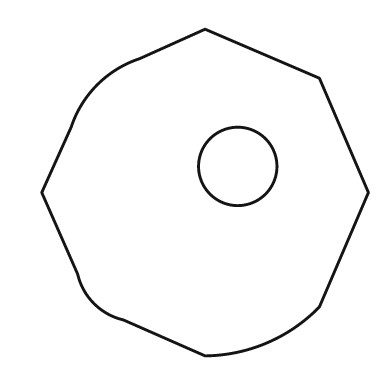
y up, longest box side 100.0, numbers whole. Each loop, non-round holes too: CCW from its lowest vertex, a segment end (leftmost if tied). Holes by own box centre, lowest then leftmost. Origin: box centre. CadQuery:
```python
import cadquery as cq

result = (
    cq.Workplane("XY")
    .moveTo(0.0, -50.0)
    .threePointArc((19.0, -46.0), (35.0, -35.0))
    .lineTo(50.0, 0.0)
    .lineTo(35.0, 35.0)
    .lineTo(0.0, 50.0)
    .lineTo(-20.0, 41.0)
    .threePointArc((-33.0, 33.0), (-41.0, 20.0))
    .lineTo(-50.0, 0.0)
    .lineTo(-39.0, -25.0)
    .threePointArc((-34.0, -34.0), (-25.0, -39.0))
    .close()
    .moveTo(10.0, 8.0)
    .circle(12.0)
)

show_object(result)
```